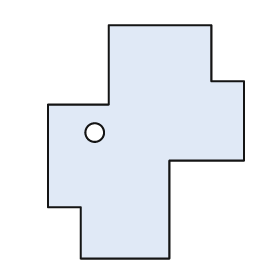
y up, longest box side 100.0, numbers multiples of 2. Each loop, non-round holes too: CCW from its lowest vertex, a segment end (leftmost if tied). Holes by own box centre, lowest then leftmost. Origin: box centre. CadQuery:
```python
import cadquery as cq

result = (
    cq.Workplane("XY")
    .moveTo(-28.0, -50.0)
    .lineTo(10.0, -50.0)
    .lineTo(10.0, -8.0)
    .lineTo(42.0, -8.0)
    .lineTo(42.0, 26.0)
    .lineTo(28.0, 26.0)
    .lineTo(28.0, 50.0)
    .lineTo(-16.0, 50.0)
    .lineTo(-16.0, 16.0)
    .lineTo(-42.0, 16.0)
    .lineTo(-42.0, -28.0)
    .lineTo(-28.0, -28.0)
    .close()
    .moveTo(-22.0, 4.0)
    .circle(4.0)
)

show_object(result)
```